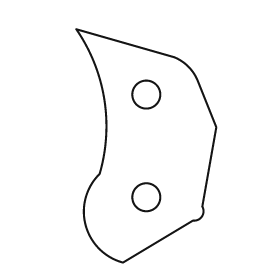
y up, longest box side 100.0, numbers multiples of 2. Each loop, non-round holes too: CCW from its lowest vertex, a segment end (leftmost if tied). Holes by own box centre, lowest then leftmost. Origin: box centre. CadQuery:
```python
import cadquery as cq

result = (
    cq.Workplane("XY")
    .moveTo(-10.0, -50.0)
    .lineTo(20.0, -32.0)
    .threePointArc((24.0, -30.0), (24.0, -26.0))
    .lineTo(30.0, 8.0)
    .lineTo(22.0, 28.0)
    .threePointArc((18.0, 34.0), (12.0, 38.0))
    .lineTo(-30.0, 50.0)
    .threePointArc((-18.0, 20.0), (-20.0, -12.0))
    .threePointArc((-26.0, -34.0), (-10.0, -50.0))
    .close()
    .moveTo(0.0, -22.0)
    .circle(6.0)
    .moveTo(0.0, 22.0)
    .circle(6.0)
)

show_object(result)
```